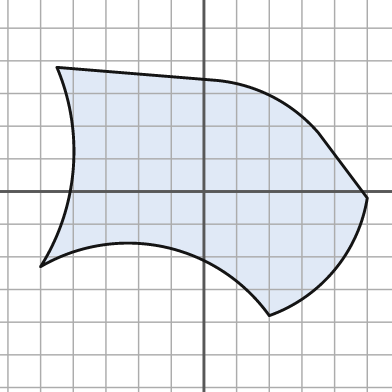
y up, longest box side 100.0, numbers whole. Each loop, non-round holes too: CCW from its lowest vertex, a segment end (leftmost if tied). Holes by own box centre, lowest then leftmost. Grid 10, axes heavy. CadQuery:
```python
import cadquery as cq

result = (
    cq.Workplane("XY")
    .moveTo(20.0, -38.0)
    .threePointArc((40.0, -24.0), (50.0, -2.0))
    .lineTo(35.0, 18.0)
    .threePointArc((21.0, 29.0), (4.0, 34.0))
    .lineTo(-45.0, 38.0)
    .threePointArc((-40.0, 7.0), (-50.0, -23.0))
    .threePointArc((-12.0, -17.0), (20.0, -38.0))
    .close()
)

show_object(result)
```